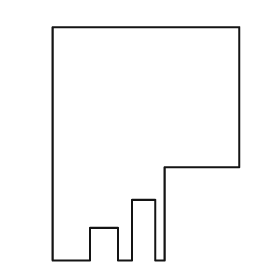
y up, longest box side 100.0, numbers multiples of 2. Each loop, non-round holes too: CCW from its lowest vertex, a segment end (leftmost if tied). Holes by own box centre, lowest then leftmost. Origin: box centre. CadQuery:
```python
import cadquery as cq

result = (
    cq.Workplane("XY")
    .moveTo(-40.0, -50.0)
    .lineTo(-24.0, -50.0)
    .lineTo(-24.0, -36.0)
    .lineTo(-12.0, -36.0)
    .lineTo(-12.0, -50.0)
    .lineTo(-6.0, -50.0)
    .lineTo(-6.0, -24.0)
    .lineTo(4.0, -24.0)
    .lineTo(4.0, -50.0)
    .lineTo(8.0, -50.0)
    .lineTo(8.0, -10.0)
    .lineTo(40.0, -10.0)
    .lineTo(40.0, 50.0)
    .lineTo(-40.0, 50.0)
    .close()
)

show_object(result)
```